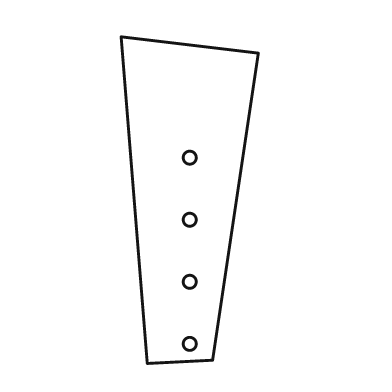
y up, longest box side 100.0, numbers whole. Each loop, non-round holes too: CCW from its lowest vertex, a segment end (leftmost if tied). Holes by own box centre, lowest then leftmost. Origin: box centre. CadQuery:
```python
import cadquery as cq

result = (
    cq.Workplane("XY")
    .moveTo(-13.0, -50.0)
    .lineTo(7.0, -49.0)
    .lineTo(21.0, 45.0)
    .lineTo(-21.0, 50.0)
    .close()
    .moveTo(0.0, -44.0)
    .circle(2.0)
    .moveTo(0.0, -25.0)
    .circle(2.0)
    .moveTo(0.0, -6.0)
    .circle(2.0)
    .moveTo(0.0, 13.0)
    .circle(2.0)
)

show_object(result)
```